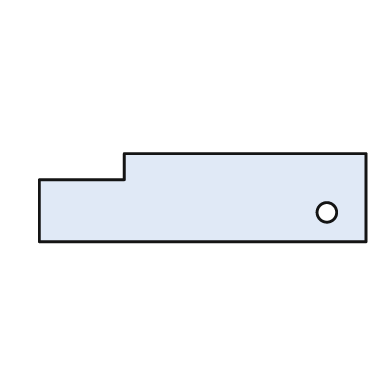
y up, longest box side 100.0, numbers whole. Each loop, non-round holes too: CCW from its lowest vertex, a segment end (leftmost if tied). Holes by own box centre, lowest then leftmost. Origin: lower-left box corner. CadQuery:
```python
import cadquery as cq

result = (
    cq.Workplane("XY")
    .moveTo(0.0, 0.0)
    .lineTo(100.0, 0.0)
    .lineTo(100.0, 27.0)
    .lineTo(26.0, 27.0)
    .lineTo(26.0, 19.0)
    .lineTo(0.0, 19.0)
    .close()
    .moveTo(88.0, 9.0)
    .circle(3.0)
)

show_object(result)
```